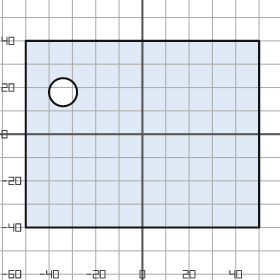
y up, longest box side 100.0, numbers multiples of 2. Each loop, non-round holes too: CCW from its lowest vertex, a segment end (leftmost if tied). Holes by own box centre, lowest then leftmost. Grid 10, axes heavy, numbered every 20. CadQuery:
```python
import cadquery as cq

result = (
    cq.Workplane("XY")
    .moveTo(-50.0, -40.0)
    .lineTo(50.0, -40.0)
    .lineTo(50.0, 40.0)
    .lineTo(-50.0, 40.0)
    .close()
    .moveTo(-34.0, 18.0)
    .circle(6.0)
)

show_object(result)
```